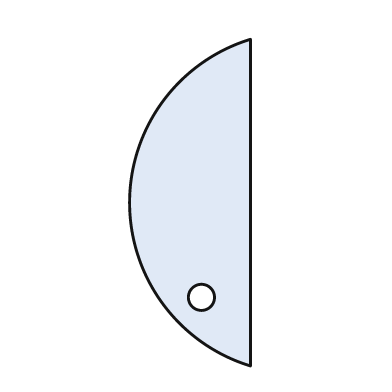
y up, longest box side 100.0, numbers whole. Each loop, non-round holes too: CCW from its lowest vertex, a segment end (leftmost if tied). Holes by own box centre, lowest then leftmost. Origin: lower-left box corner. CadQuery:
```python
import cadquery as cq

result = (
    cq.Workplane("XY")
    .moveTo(37.0, 0.0)
    .lineTo(37.0, 100.0)
    .threePointArc((0.0, 50.0), (37.0, 0.0))
    .close()
    .moveTo(22.0, 21.0)
    .circle(4.0)
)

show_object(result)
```